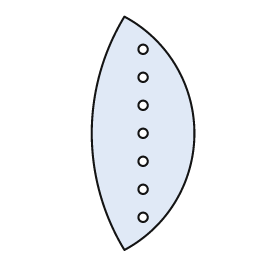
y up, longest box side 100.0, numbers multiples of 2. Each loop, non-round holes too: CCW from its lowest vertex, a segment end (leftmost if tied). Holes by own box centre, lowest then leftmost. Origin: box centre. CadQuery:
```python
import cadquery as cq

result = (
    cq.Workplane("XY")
    .moveTo(-8.0, -50.0)
    .threePointArc((22.0, 0.0), (-8.0, 50.0))
    .threePointArc((-22.0, 0.0), (-8.0, -50.0))
    .close()
    .moveTo(0.0, -36.0)
    .circle(2.0)
    .moveTo(0.0, -24.0)
    .circle(2.0)
    .moveTo(0.0, -12.0)
    .circle(2.0)
    .moveTo(0.0, 0.0)
    .circle(2.0)
    .moveTo(0.0, 12.0)
    .circle(2.0)
    .moveTo(0.0, 24.0)
    .circle(2.0)
    .moveTo(0.0, 36.0)
    .circle(2.0)
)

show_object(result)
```